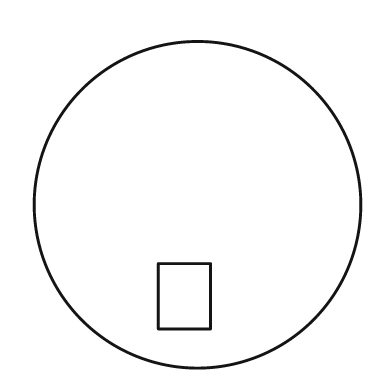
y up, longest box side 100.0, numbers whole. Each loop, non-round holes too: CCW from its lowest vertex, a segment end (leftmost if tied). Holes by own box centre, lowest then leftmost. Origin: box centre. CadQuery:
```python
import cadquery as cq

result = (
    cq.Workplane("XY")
    .moveTo(0.0, 0.0)
    .circle(50.0)
    .moveTo(-12.0, -38.0)
    .lineTo(4.0, -38.0)
    .lineTo(4.0, -18.0)
    .lineTo(-12.0, -18.0)
    .close()
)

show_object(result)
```